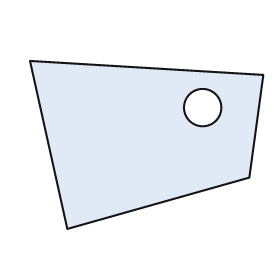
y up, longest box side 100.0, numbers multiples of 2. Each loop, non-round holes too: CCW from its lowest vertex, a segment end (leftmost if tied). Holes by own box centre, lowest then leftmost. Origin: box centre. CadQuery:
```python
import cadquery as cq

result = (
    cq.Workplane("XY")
    .moveTo(-34.0, -36.0)
    .lineTo(44.0, -14.0)
    .lineTo(50.0, 30.0)
    .lineTo(-50.0, 36.0)
    .close()
    .moveTo(24.0, 16.0)
    .circle(8.0)
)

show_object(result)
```